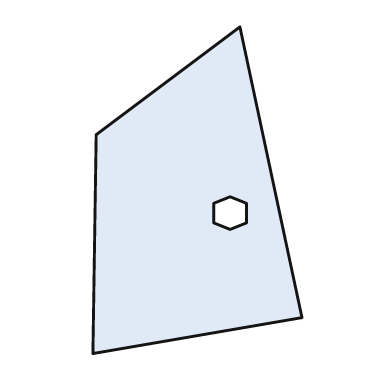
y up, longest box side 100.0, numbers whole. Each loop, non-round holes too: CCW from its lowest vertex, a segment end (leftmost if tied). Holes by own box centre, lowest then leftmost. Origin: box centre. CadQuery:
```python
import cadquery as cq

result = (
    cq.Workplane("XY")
    .moveTo(-32.0, -50.0)
    .lineTo(32.0, -39.0)
    .lineTo(13.0, 50.0)
    .lineTo(-31.0, 17.0)
    .close()
    .moveTo(10.0, -12.0)
    .lineTo(15.0, -10.0)
    .lineTo(15.0, -4.0)
    .lineTo(10.0, -2.0)
    .lineTo(5.0, -4.0)
    .lineTo(5.0, -10.0)
    .close()
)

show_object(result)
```